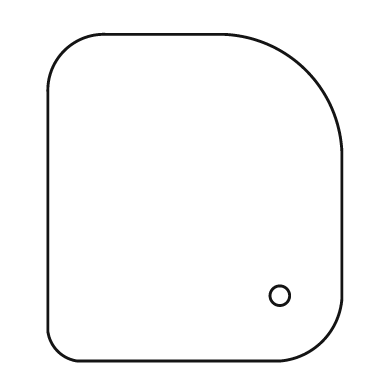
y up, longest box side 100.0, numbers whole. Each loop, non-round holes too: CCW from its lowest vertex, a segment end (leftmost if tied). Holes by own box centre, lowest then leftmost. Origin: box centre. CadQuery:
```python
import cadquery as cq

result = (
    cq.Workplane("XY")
    .moveTo(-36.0, -50.0)
    .lineTo(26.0, -50.0)
    .threePointArc((39.0, -44.0), (45.0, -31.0))
    .lineTo(45.0, 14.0)
    .threePointArc((34.0, 39.0), (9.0, 50.0))
    .lineTo(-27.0, 50.0)
    .threePointArc((-40.0, 45.0), (-45.0, 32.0))
    .lineTo(-45.0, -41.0)
    .threePointArc((-42.0, -47.0), (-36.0, -50.0))
    .close()
    .moveTo(26.0, -30.0)
    .circle(3.0)
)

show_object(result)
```